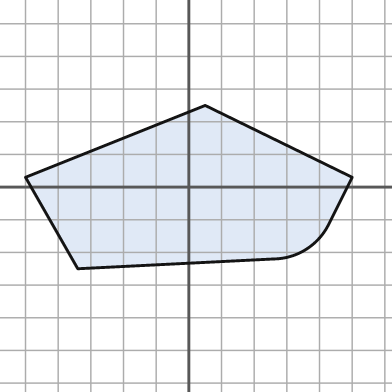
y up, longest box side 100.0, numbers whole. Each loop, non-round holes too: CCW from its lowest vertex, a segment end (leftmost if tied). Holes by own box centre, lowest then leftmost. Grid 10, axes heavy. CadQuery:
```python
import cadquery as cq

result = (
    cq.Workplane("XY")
    .moveTo(-34.0, -25.0)
    .lineTo(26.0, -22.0)
    .threePointArc((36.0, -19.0), (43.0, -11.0))
    .lineTo(50.0, 3.0)
    .lineTo(5.0, 25.0)
    .lineTo(-50.0, 3.0)
    .close()
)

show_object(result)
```